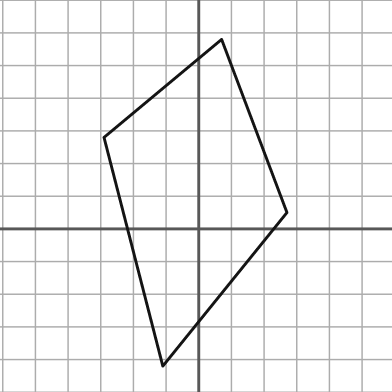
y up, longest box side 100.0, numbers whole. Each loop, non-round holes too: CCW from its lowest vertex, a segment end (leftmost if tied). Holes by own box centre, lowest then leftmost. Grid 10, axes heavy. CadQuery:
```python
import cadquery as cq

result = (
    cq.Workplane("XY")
    .moveTo(-11.0, -42.0)
    .lineTo(27.0, 5.0)
    .lineTo(7.0, 58.0)
    .lineTo(-29.0, 28.0)
    .close()
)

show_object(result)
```